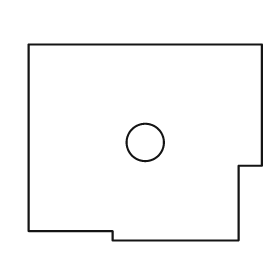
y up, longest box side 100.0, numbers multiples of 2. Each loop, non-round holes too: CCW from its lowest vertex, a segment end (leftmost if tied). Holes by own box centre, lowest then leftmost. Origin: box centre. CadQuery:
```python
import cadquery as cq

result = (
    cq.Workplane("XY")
    .moveTo(-14.0, -42.0)
    .lineTo(40.0, -42.0)
    .lineTo(40.0, -10.0)
    .lineTo(50.0, -10.0)
    .lineTo(50.0, 42.0)
    .lineTo(-50.0, 42.0)
    .lineTo(-50.0, -38.0)
    .lineTo(-14.0, -38.0)
    .close()
    .moveTo(0.0, 0.0)
    .circle(8.0)
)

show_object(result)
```